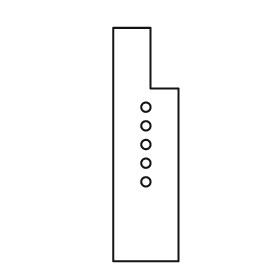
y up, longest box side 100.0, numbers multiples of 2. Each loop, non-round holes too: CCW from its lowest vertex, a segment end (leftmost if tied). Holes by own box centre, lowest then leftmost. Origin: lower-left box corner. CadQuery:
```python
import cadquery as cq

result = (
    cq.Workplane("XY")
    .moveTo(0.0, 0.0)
    .lineTo(28.0, 0.0)
    .lineTo(28.0, 74.0)
    .lineTo(16.0, 74.0)
    .lineTo(16.0, 100.0)
    .lineTo(0.0, 100.0)
    .close()
    .moveTo(14.0, 34.0)
    .circle(2.0)
    .moveTo(14.0, 42.0)
    .circle(2.0)
    .moveTo(14.0, 50.0)
    .circle(2.0)
    .moveTo(14.0, 58.0)
    .circle(2.0)
    .moveTo(14.0, 66.0)
    .circle(2.0)
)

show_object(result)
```